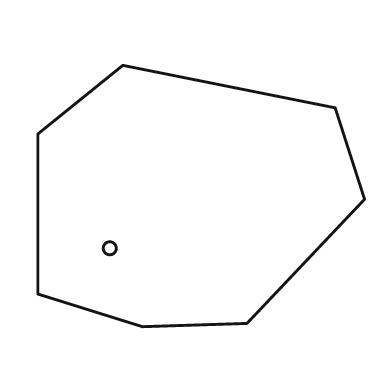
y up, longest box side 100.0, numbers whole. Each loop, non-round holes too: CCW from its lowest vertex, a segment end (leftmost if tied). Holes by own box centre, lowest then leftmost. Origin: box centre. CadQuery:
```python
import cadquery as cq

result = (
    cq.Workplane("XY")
    .moveTo(-18.0, -40.0)
    .lineTo(14.0, -39.0)
    .lineTo(50.0, -1.0)
    .lineTo(41.0, 27.0)
    .lineTo(-24.0, 40.0)
    .lineTo(-50.0, 19.0)
    .lineTo(-50.0, -30.0)
    .close()
    .moveTo(-28.0, -16.0)
    .circle(2.0)
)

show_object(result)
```